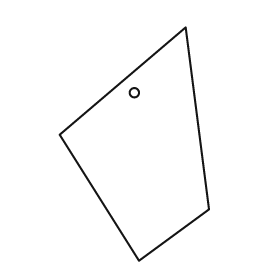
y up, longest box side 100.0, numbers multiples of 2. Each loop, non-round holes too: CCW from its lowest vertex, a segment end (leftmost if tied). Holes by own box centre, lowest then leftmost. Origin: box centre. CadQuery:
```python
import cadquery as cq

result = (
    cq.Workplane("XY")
    .moveTo(2.0, -50.0)
    .lineTo(32.0, -28.0)
    .lineTo(22.0, 50.0)
    .lineTo(-32.0, 4.0)
    .close()
    .moveTo(0.0, 22.0)
    .circle(2.0)
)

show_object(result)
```